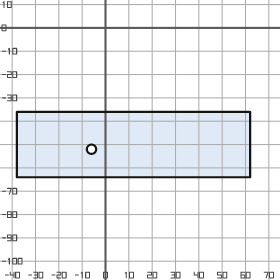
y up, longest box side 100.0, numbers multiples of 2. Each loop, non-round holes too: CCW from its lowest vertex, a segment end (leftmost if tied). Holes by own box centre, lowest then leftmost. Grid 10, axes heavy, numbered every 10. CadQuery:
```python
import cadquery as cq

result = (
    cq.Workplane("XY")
    .moveTo(-38.0, -64.0)
    .lineTo(62.0, -64.0)
    .lineTo(62.0, -36.0)
    .lineTo(-38.0, -36.0)
    .close()
    .moveTo(-6.0, -52.0)
    .circle(2.0)
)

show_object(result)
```